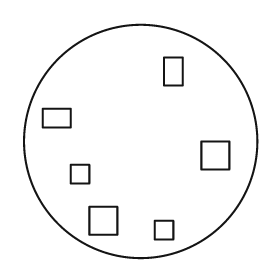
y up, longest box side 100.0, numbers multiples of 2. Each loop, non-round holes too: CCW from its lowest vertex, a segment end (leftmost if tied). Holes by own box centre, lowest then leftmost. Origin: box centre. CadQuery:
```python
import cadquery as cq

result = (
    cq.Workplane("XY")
    .moveTo(0.0, 0.0)
    .circle(50.0)
    .moveTo(6.0, -42.0)
    .lineTo(14.0, -42.0)
    .lineTo(14.0, -34.0)
    .lineTo(6.0, -34.0)
    .close()
    .moveTo(-22.0, -40.0)
    .lineTo(-10.0, -40.0)
    .lineTo(-10.0, -28.0)
    .lineTo(-22.0, -28.0)
    .close()
    .moveTo(-30.0, -18.0)
    .lineTo(-22.0, -18.0)
    .lineTo(-22.0, -10.0)
    .lineTo(-30.0, -10.0)
    .close()
    .moveTo(26.0, -12.0)
    .lineTo(38.0, -12.0)
    .lineTo(38.0, 0.0)
    .lineTo(26.0, 0.0)
    .close()
    .moveTo(-42.0, 6.0)
    .lineTo(-30.0, 6.0)
    .lineTo(-30.0, 14.0)
    .lineTo(-42.0, 14.0)
    .close()
    .moveTo(10.0, 24.0)
    .lineTo(18.0, 24.0)
    .lineTo(18.0, 36.0)
    .lineTo(10.0, 36.0)
    .close()
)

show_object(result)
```